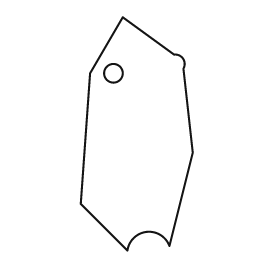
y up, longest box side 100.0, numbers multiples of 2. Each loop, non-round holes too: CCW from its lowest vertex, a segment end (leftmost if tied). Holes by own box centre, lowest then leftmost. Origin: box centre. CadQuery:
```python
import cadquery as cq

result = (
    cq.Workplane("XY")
    .moveTo(-4.0, -50.0)
    .threePointArc((4.0, -42.0), (14.0, -48.0))
    .lineTo(24.0, -8.0)
    .lineTo(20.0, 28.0)
    .threePointArc((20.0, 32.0), (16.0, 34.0))
    .lineTo(-6.0, 50.0)
    .lineTo(-20.0, 26.0)
    .lineTo(-24.0, -30.0)
    .close()
    .moveTo(-10.0, 26.0)
    .circle(4.0)
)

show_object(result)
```